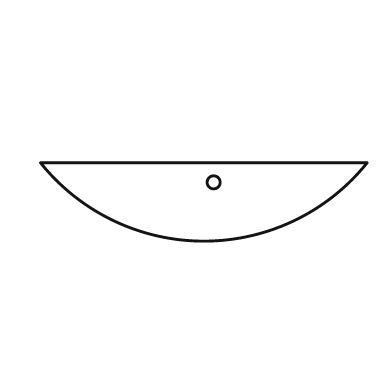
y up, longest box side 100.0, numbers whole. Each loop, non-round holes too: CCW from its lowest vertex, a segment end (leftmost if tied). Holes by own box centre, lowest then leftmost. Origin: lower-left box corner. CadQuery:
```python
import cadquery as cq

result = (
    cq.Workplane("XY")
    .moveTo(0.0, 24.0)
    .threePointArc((50.0, 0.0), (100.0, 24.0))
    .close()
    .moveTo(53.0, 18.0)
    .circle(2.0)
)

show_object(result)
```